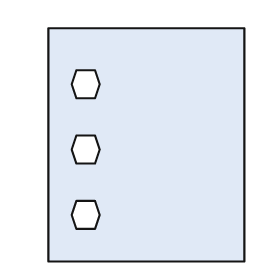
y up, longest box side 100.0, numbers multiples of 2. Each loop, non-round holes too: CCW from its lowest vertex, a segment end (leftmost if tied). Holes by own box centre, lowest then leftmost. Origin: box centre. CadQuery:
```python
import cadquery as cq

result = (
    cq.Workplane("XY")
    .moveTo(-42.0, -50.0)
    .lineTo(42.0, -50.0)
    .lineTo(42.0, 50.0)
    .lineTo(-42.0, 50.0)
    .close()
    .moveTo(-30.0, -36.0)
    .lineTo(-22.0, -36.0)
    .lineTo(-20.0, -30.0)
    .lineTo(-22.0, -24.0)
    .lineTo(-30.0, -24.0)
    .lineTo(-32.0, -30.0)
    .close()
    .moveTo(-30.0, -8.0)
    .lineTo(-22.0, -8.0)
    .lineTo(-20.0, -2.0)
    .lineTo(-22.0, 4.0)
    .lineTo(-30.0, 4.0)
    .lineTo(-32.0, -2.0)
    .close()
    .moveTo(-30.0, 20.0)
    .lineTo(-22.0, 20.0)
    .lineTo(-20.0, 26.0)
    .lineTo(-22.0, 32.0)
    .lineTo(-30.0, 32.0)
    .lineTo(-32.0, 26.0)
    .close()
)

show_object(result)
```